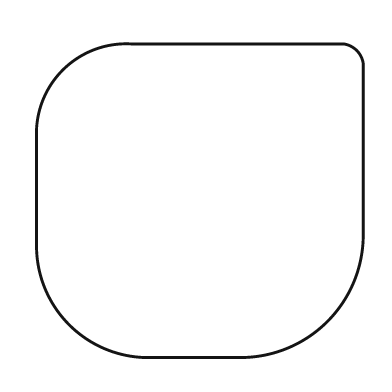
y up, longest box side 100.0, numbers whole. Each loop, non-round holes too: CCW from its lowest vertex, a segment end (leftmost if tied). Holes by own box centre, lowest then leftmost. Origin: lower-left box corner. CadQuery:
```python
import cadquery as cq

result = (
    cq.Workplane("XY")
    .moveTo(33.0, 0.0)
    .lineTo(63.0, 0.0)
    .threePointArc((89.0, 11.0), (100.0, 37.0))
    .lineTo(100.0, 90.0)
    .threePointArc((98.0, 94.0), (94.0, 96.0))
    .lineTo(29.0, 96.0)
    .threePointArc((8.0, 88.0), (0.0, 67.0))
    .lineTo(0.0, 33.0)
    .threePointArc((10.0, 10.0), (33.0, 0.0))
    .close()
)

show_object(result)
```